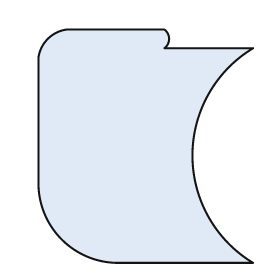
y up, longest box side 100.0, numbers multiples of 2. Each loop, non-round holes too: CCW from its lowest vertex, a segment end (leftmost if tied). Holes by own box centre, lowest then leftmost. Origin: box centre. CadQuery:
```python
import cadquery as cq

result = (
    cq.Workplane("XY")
    .moveTo(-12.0, -50.0)
    .lineTo(46.0, -50.0)
    .threePointArc((20.0, -4.0), (46.0, 42.0))
    .lineTo(8.0, 42.0)
    .threePointArc((10.0, 46.0), (8.0, 50.0))
    .lineTo(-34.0, 50.0)
    .threePointArc((-42.0, 46.0), (-46.0, 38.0))
    .lineTo(-46.0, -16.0)
    .threePointArc((-36.0, -40.0), (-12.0, -50.0))
    .close()
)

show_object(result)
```